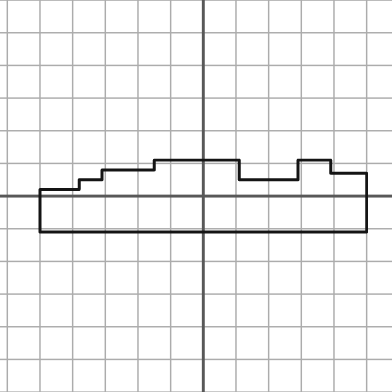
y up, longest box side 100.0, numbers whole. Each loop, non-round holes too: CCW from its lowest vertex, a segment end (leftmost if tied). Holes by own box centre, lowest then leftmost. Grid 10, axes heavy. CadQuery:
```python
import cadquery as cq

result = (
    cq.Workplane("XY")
    .moveTo(-50.0, -11.0)
    .lineTo(50.0, -11.0)
    .lineTo(50.0, 7.0)
    .lineTo(39.0, 7.0)
    .lineTo(39.0, 11.0)
    .lineTo(29.0, 11.0)
    .lineTo(29.0, 5.0)
    .lineTo(11.0, 5.0)
    .lineTo(11.0, 11.0)
    .lineTo(-15.0, 11.0)
    .lineTo(-15.0, 8.0)
    .lineTo(-31.0, 8.0)
    .lineTo(-31.0, 5.0)
    .lineTo(-38.0, 5.0)
    .lineTo(-38.0, 2.0)
    .lineTo(-50.0, 2.0)
    .close()
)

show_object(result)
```